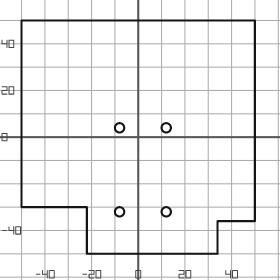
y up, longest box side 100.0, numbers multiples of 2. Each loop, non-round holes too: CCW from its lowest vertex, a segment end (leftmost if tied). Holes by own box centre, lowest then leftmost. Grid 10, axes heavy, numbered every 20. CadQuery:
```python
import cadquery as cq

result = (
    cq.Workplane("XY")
    .moveTo(-22.0, -50.0)
    .lineTo(34.0, -50.0)
    .lineTo(34.0, -36.0)
    .lineTo(50.0, -36.0)
    .lineTo(50.0, 50.0)
    .lineTo(-50.0, 50.0)
    .lineTo(-50.0, -30.0)
    .lineTo(-22.0, -30.0)
    .close()
    .moveTo(-8.0, -32.0)
    .circle(2.0)
    .moveTo(12.0, -32.0)
    .circle(2.0)
    .moveTo(-8.0, 4.0)
    .circle(2.0)
    .moveTo(12.0, 4.0)
    .circle(2.0)
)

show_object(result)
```